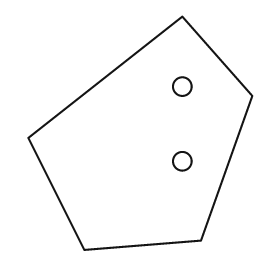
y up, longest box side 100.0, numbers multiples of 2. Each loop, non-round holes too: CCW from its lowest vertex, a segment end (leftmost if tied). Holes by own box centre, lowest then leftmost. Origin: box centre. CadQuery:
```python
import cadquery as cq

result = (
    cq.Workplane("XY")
    .moveTo(-24.0, -50.0)
    .lineTo(26.0, -46.0)
    .lineTo(48.0, 16.0)
    .lineTo(18.0, 50.0)
    .lineTo(-48.0, -2.0)
    .close()
    .moveTo(18.0, -12.0)
    .circle(4.0)
    .moveTo(18.0, 20.0)
    .circle(4.0)
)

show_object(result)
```